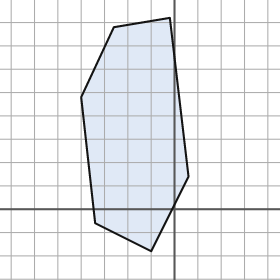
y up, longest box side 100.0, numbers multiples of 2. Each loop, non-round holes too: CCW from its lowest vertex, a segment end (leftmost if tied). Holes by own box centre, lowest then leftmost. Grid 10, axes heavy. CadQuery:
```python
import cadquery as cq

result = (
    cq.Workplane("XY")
    .moveTo(-10.0, -18.0)
    .lineTo(6.0, 14.0)
    .lineTo(-2.0, 82.0)
    .lineTo(-26.0, 78.0)
    .lineTo(-40.0, 48.0)
    .lineTo(-34.0, -6.0)
    .close()
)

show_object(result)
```